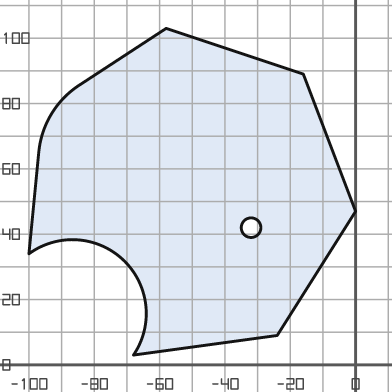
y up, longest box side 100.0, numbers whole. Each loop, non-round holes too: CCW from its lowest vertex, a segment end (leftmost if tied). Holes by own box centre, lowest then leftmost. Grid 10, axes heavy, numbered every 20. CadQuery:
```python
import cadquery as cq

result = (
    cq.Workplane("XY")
    .moveTo(-68.0, 3.0)
    .lineTo(-24.0, 9.0)
    .lineTo(0.0, 47.0)
    .lineTo(-16.0, 89.0)
    .lineTo(-58.0, 103.0)
    .lineTo(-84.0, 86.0)
    .threePointArc((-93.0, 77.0), (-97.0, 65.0))
    .lineTo(-100.0, 34.0)
    .threePointArc((-71.0, 32.0), (-68.0, 3.0))
    .close()
    .moveTo(-32.0, 42.0)
    .circle(3.0)
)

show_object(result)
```